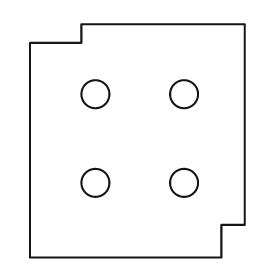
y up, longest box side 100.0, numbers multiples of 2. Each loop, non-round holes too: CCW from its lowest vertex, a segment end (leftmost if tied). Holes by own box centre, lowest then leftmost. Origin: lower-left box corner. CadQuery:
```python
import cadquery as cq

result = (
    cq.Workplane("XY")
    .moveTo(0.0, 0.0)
    .lineTo(82.0, 0.0)
    .lineTo(82.0, 14.0)
    .lineTo(92.0, 14.0)
    .lineTo(92.0, 100.0)
    .lineTo(22.0, 100.0)
    .lineTo(22.0, 92.0)
    .lineTo(0.0, 92.0)
    .close()
    .moveTo(28.0, 32.0)
    .circle(6.0)
    .moveTo(66.0, 32.0)
    .circle(6.0)
    .moveTo(28.0, 70.0)
    .circle(6.0)
    .moveTo(66.0, 70.0)
    .circle(6.0)
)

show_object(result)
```